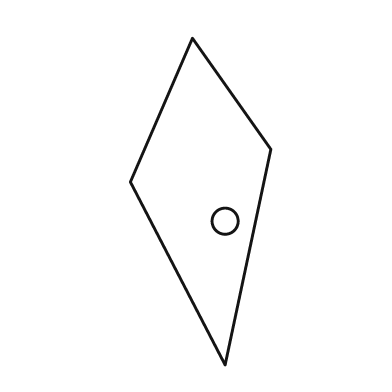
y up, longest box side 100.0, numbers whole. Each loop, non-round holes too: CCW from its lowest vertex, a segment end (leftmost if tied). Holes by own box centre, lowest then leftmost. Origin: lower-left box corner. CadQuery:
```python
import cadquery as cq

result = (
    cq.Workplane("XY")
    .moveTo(29.0, 0.0)
    .lineTo(43.0, 66.0)
    .lineTo(19.0, 100.0)
    .lineTo(0.0, 56.0)
    .close()
    .moveTo(29.0, 44.0)
    .circle(4.0)
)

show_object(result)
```